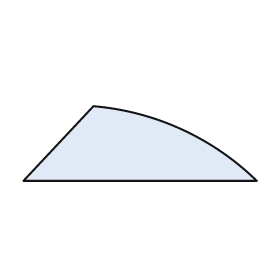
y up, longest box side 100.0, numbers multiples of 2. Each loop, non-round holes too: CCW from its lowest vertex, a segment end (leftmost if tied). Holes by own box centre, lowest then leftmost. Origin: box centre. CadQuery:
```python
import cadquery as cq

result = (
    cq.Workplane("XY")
    .moveTo(-50.0, -16.0)
    .lineTo(50.0, -16.0)
    .threePointArc((18.0, 6.0), (-20.0, 16.0))
    .close()
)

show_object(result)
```